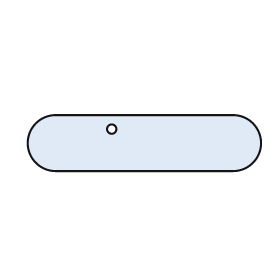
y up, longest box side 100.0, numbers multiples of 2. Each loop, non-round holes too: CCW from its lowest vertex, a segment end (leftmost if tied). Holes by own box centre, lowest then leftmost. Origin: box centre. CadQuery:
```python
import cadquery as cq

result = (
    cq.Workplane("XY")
    .moveTo(-38.0, -12.0)
    .lineTo(38.0, -12.0)
    .threePointArc((50.0, 0.0), (38.0, 12.0))
    .lineTo(-38.0, 12.0)
    .threePointArc((-50.0, 0.0), (-38.0, -12.0))
    .close()
    .moveTo(-14.0, 6.0)
    .circle(2.0)
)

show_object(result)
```